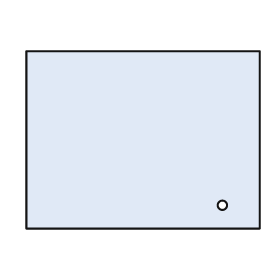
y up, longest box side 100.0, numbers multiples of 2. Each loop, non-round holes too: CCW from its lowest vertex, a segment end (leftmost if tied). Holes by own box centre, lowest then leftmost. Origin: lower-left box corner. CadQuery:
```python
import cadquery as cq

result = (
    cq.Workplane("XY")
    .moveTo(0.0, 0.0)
    .lineTo(100.0, 0.0)
    .lineTo(100.0, 76.0)
    .lineTo(0.0, 76.0)
    .close()
    .moveTo(84.0, 10.0)
    .circle(2.0)
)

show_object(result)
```